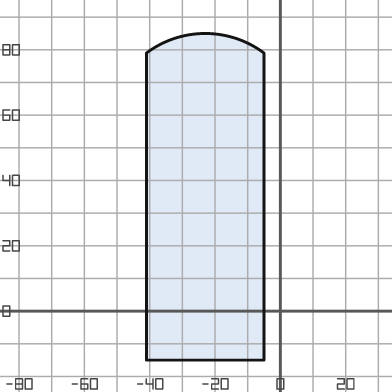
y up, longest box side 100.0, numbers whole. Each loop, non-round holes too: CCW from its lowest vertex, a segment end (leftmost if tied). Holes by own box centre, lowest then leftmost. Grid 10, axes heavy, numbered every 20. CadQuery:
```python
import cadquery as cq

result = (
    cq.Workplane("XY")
    .moveTo(-41.0, -15.0)
    .lineTo(-5.0, -15.0)
    .lineTo(-5.0, 79.0)
    .threePointArc((-23.0, 85.0), (-41.0, 79.0))
    .close()
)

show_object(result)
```